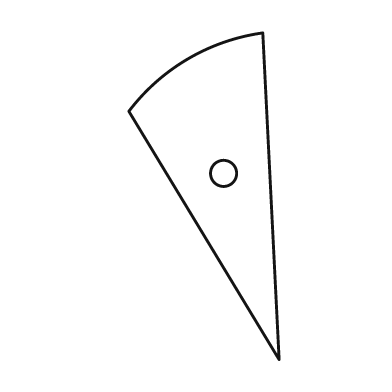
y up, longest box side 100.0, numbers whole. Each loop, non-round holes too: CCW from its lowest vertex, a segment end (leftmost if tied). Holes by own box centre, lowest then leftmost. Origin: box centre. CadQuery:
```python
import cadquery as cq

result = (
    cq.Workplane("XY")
    .moveTo(23.0, -50.0)
    .lineTo(18.0, 50.0)
    .threePointArc((-5.0, 42.0), (-23.0, 26.0))
    .close()
    .moveTo(6.0, 7.0)
    .circle(4.0)
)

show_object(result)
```